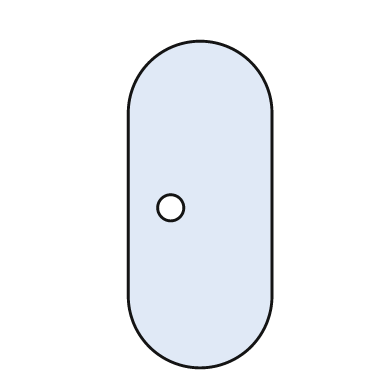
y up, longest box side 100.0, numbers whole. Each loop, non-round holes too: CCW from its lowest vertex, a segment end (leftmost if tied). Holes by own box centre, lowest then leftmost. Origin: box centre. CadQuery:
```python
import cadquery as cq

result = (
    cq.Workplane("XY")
    .moveTo(-22.0, -28.0)
    .threePointArc((0.0, -50.0), (22.0, -28.0))
    .lineTo(22.0, 28.0)
    .threePointArc((0.0, 50.0), (-22.0, 28.0))
    .close()
    .moveTo(-9.0, -1.0)
    .circle(4.0)
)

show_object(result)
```